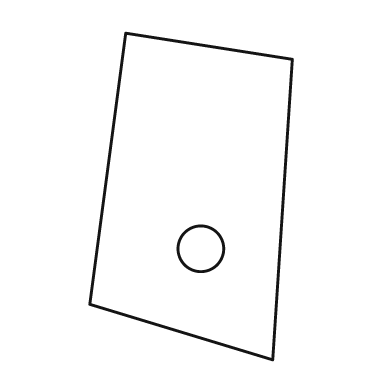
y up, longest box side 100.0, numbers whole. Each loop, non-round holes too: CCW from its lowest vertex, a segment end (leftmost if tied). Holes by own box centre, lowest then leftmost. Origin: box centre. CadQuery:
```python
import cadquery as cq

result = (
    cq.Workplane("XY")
    .moveTo(25.0, -50.0)
    .lineTo(31.0, 42.0)
    .lineTo(-20.0, 50.0)
    .lineTo(-31.0, -33.0)
    .close()
    .moveTo(3.0, -16.0)
    .circle(7.0)
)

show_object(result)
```